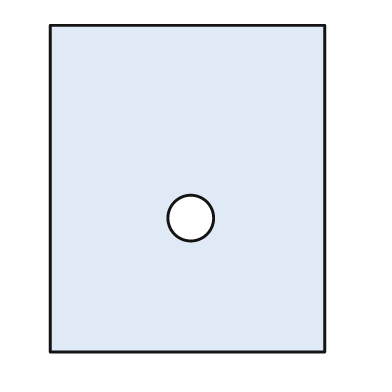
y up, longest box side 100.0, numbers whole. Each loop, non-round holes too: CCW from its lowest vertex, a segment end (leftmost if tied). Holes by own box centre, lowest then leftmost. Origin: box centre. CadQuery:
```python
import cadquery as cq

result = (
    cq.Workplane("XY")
    .moveTo(-42.0, -50.0)
    .lineTo(42.0, -50.0)
    .lineTo(42.0, 50.0)
    .lineTo(-42.0, 50.0)
    .close()
    .moveTo(1.0, -9.0)
    .circle(7.0)
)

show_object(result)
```